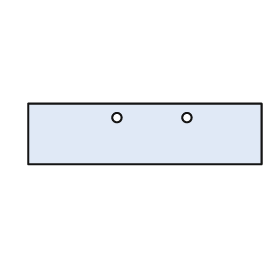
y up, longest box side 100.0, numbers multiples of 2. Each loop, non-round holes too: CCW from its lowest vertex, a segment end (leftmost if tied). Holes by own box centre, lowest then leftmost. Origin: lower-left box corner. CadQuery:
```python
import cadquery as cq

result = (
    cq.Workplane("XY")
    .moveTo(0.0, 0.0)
    .lineTo(100.0, 0.0)
    .lineTo(100.0, 26.0)
    .lineTo(0.0, 26.0)
    .close()
    .moveTo(38.0, 20.0)
    .circle(2.0)
    .moveTo(68.0, 20.0)
    .circle(2.0)
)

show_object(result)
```